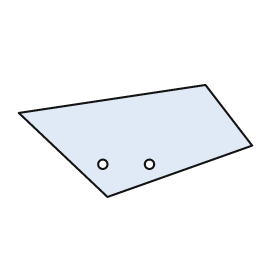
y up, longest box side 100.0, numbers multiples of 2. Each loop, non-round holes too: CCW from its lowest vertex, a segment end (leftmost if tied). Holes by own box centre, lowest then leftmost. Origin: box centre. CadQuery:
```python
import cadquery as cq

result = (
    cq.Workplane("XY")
    .moveTo(-12.0, -24.0)
    .lineTo(50.0, -2.0)
    .lineTo(30.0, 24.0)
    .lineTo(-50.0, 12.0)
    .close()
    .moveTo(-14.0, -10.0)
    .circle(2.0)
    .moveTo(6.0, -10.0)
    .circle(2.0)
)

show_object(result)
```